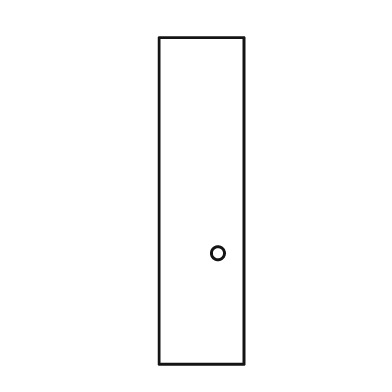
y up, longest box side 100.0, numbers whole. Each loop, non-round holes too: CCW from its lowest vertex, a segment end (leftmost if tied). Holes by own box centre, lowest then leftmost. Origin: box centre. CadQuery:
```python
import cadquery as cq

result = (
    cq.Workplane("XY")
    .moveTo(-13.0, -50.0)
    .lineTo(13.0, -50.0)
    .lineTo(13.0, 50.0)
    .lineTo(-13.0, 50.0)
    .close()
    .moveTo(5.0, -16.0)
    .circle(2.0)
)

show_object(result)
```